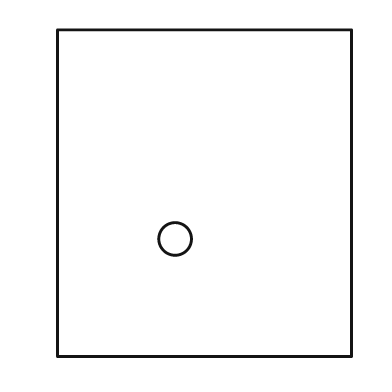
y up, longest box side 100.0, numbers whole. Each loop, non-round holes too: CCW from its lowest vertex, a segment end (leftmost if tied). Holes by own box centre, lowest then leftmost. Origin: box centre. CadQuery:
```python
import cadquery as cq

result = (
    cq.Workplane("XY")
    .moveTo(-45.0, -50.0)
    .lineTo(45.0, -50.0)
    .lineTo(45.0, 50.0)
    .lineTo(-45.0, 50.0)
    .close()
    .moveTo(-9.0, -14.0)
    .circle(5.0)
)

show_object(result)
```